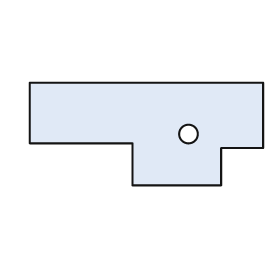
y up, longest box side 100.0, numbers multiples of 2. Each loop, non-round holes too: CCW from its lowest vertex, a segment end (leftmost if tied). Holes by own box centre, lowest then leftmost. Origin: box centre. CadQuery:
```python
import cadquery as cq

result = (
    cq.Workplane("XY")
    .moveTo(-6.0, -22.0)
    .lineTo(32.0, -22.0)
    .lineTo(32.0, -6.0)
    .lineTo(50.0, -6.0)
    .lineTo(50.0, 22.0)
    .lineTo(-50.0, 22.0)
    .lineTo(-50.0, -4.0)
    .lineTo(-6.0, -4.0)
    .close()
    .moveTo(18.0, 0.0)
    .circle(4.0)
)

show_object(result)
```